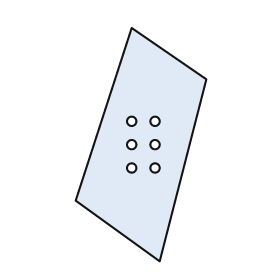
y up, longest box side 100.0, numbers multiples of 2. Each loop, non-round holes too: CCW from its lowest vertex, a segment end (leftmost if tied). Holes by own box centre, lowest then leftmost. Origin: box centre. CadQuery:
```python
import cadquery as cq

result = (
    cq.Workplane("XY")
    .moveTo(8.0, -50.0)
    .lineTo(28.0, 28.0)
    .lineTo(-4.0, 50.0)
    .lineTo(-28.0, -24.0)
    .close()
    .moveTo(-4.0, -10.0)
    .circle(2.0)
    .moveTo(6.0, -10.0)
    .circle(2.0)
    .moveTo(-4.0, 0.0)
    .circle(2.0)
    .moveTo(6.0, 0.0)
    .circle(2.0)
    .moveTo(-4.0, 10.0)
    .circle(2.0)
    .moveTo(6.0, 10.0)
    .circle(2.0)
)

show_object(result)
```